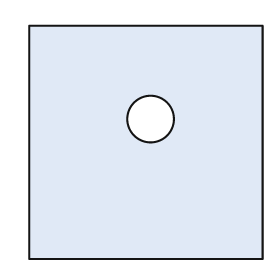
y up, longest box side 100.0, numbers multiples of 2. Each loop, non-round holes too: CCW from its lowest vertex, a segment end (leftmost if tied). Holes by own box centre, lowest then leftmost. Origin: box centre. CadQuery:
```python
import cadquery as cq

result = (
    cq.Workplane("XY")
    .moveTo(-50.0, -50.0)
    .lineTo(50.0, -50.0)
    .lineTo(50.0, 50.0)
    .lineTo(-50.0, 50.0)
    .close()
    .moveTo(2.0, 10.0)
    .circle(10.0)
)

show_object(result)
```